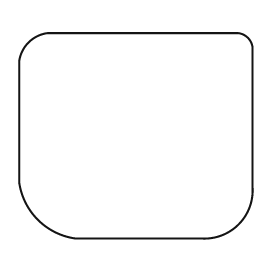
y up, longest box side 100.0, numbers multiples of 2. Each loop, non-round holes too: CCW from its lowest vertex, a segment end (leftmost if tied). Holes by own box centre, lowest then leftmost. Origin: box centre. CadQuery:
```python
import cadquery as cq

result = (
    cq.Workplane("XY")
    .moveTo(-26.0, -44.0)
    .lineTo(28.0, -44.0)
    .threePointArc((44.0, -38.0), (50.0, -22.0))
    .lineTo(50.0, 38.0)
    .threePointArc((48.0, 42.0), (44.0, 44.0))
    .lineTo(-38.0, 44.0)
    .threePointArc((-46.0, 40.0), (-50.0, 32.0))
    .lineTo(-50.0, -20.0)
    .threePointArc((-42.0, -36.0), (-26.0, -44.0))
    .close()
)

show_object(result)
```